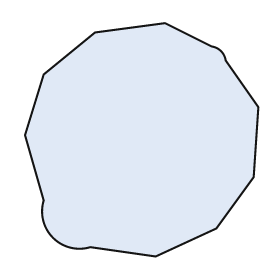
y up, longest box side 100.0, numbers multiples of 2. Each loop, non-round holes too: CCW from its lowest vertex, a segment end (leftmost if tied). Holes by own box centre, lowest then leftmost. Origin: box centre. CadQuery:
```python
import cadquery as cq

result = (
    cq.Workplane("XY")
    .moveTo(6.0, -50.0)
    .lineTo(32.0, -38.0)
    .lineTo(48.0, -16.0)
    .lineTo(50.0, 14.0)
    .lineTo(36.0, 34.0)
    .threePointArc((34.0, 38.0), (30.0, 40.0))
    .lineTo(10.0, 50.0)
    .lineTo(-20.0, 46.0)
    .lineTo(-42.0, 28.0)
    .lineTo(-50.0, 2.0)
    .lineTo(-42.0, -26.0)
    .threePointArc((-38.0, -42.0), (-22.0, -46.0))
    .close()
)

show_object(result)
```